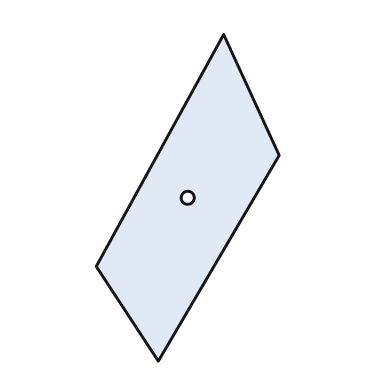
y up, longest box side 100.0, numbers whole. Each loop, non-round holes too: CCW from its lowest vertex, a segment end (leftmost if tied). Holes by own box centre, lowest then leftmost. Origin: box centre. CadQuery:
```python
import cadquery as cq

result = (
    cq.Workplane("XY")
    .moveTo(-9.0, -50.0)
    .lineTo(28.0, 13.0)
    .lineTo(11.0, 50.0)
    .lineTo(-28.0, -21.0)
    .close()
    .moveTo(0.0, 0.0)
    .circle(2.0)
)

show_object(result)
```